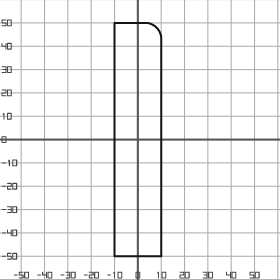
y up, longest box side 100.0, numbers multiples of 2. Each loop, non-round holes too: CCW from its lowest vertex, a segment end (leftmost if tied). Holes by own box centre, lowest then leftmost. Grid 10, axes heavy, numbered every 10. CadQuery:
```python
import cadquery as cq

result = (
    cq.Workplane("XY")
    .moveTo(-10.0, -50.0)
    .lineTo(10.0, -50.0)
    .lineTo(10.0, 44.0)
    .threePointArc((8.0, 48.0), (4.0, 50.0))
    .lineTo(-10.0, 50.0)
    .close()
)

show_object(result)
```